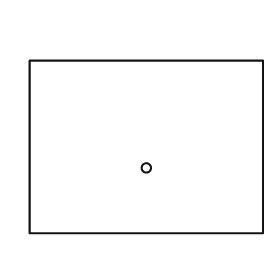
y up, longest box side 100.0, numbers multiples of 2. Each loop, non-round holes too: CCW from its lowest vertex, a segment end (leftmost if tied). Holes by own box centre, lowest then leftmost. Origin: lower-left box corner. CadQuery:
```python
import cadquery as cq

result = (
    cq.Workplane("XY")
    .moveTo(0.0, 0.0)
    .lineTo(100.0, 0.0)
    .lineTo(100.0, 74.0)
    .lineTo(0.0, 74.0)
    .close()
    .moveTo(50.0, 28.0)
    .circle(2.0)
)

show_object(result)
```